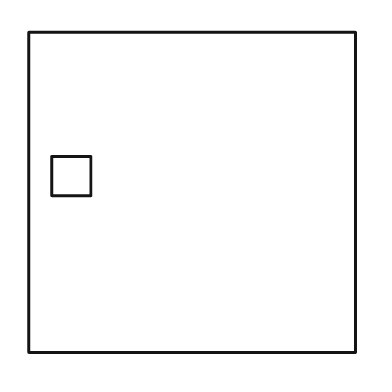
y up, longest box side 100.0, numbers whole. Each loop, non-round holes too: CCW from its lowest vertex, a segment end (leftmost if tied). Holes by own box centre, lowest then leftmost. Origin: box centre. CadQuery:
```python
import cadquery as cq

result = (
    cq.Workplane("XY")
    .moveTo(-50.0, -49.0)
    .lineTo(50.0, -49.0)
    .lineTo(50.0, 49.0)
    .lineTo(-50.0, 49.0)
    .close()
    .moveTo(-43.0, -1.0)
    .lineTo(-31.0, -1.0)
    .lineTo(-31.0, 11.0)
    .lineTo(-43.0, 11.0)
    .close()
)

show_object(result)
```